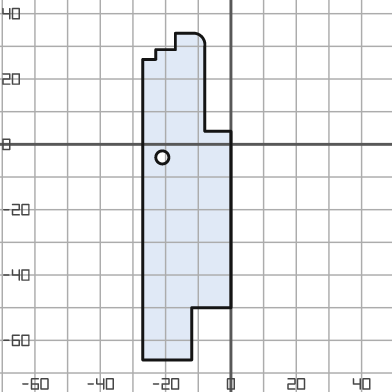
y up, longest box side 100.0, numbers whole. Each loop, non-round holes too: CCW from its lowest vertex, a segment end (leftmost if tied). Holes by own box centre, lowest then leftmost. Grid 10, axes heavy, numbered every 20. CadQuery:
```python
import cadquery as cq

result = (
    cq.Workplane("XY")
    .moveTo(-27.0, -66.0)
    .lineTo(-12.0, -66.0)
    .lineTo(-12.0, -50.0)
    .lineTo(0.0, -50.0)
    .lineTo(0.0, 4.0)
    .lineTo(-8.0, 4.0)
    .lineTo(-8.0, 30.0)
    .threePointArc((-9.0, 33.0), (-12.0, 34.0))
    .lineTo(-17.0, 34.0)
    .lineTo(-17.0, 29.0)
    .lineTo(-23.0, 29.0)
    .lineTo(-23.0, 26.0)
    .lineTo(-27.0, 26.0)
    .close()
    .moveTo(-21.0, -4.0)
    .circle(2.0)
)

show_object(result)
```